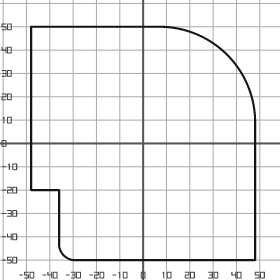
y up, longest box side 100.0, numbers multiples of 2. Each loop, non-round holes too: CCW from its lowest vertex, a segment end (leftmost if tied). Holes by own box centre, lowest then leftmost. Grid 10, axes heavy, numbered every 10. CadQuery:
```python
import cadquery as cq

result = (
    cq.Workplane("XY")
    .moveTo(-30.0, -50.0)
    .lineTo(48.0, -50.0)
    .lineTo(48.0, 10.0)
    .threePointArc((36.0, 38.0), (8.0, 50.0))
    .lineTo(-48.0, 50.0)
    .lineTo(-48.0, -20.0)
    .lineTo(-36.0, -20.0)
    .lineTo(-36.0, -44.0)
    .threePointArc((-34.0, -48.0), (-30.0, -50.0))
    .close()
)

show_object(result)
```